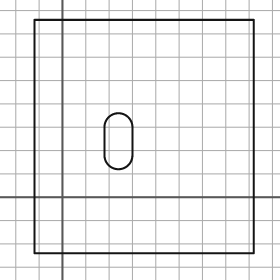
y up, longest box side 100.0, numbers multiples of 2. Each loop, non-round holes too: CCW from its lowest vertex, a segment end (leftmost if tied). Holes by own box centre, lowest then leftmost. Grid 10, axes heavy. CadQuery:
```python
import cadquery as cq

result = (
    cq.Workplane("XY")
    .moveTo(-12.0, -24.0)
    .lineTo(82.0, -24.0)
    .lineTo(82.0, 76.0)
    .lineTo(-12.0, 76.0)
    .close()
    .moveTo(18.0, 18.0)
    .threePointArc((24.0, 12.0), (30.0, 18.0))
    .lineTo(30.0, 30.0)
    .threePointArc((24.0, 36.0), (18.0, 30.0))
    .close()
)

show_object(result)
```